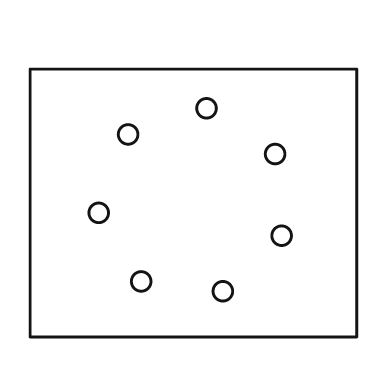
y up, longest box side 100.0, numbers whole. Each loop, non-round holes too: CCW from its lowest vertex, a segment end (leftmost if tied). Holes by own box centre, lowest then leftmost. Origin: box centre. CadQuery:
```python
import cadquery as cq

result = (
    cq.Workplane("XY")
    .moveTo(-50.0, -41.0)
    .lineTo(50.0, -41.0)
    .lineTo(50.0, 41.0)
    .lineTo(-50.0, 41.0)
    .close()
    .moveTo(9.0, -27.0)
    .circle(3.0)
    .moveTo(-16.0, -24.0)
    .circle(3.0)
    .moveTo(27.0, -10.0)
    .circle(3.0)
    .moveTo(-29.0, -3.0)
    .circle(3.0)
    .moveTo(25.0, 15.0)
    .circle(3.0)
    .moveTo(-20.0, 21.0)
    .circle(3.0)
    .moveTo(4.0, 29.0)
    .circle(3.0)
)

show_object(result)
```